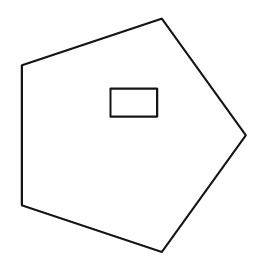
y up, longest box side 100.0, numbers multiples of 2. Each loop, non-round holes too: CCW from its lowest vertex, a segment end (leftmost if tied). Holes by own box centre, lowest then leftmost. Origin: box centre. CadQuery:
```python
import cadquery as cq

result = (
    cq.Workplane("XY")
    .moveTo(12.0, -50.0)
    .lineTo(48.0, 0.0)
    .lineTo(12.0, 50.0)
    .lineTo(-48.0, 30.0)
    .lineTo(-48.0, -30.0)
    .close()
    .moveTo(-10.0, 8.0)
    .lineTo(10.0, 8.0)
    .lineTo(10.0, 20.0)
    .lineTo(-10.0, 20.0)
    .close()
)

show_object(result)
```